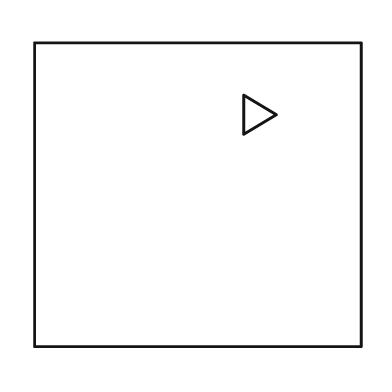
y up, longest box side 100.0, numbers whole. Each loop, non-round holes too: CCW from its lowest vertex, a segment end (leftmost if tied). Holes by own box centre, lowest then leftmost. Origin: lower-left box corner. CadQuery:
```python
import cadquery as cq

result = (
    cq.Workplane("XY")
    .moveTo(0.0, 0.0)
    .lineTo(100.0, 0.0)
    .lineTo(100.0, 93.0)
    .lineTo(0.0, 93.0)
    .close()
    .moveTo(64.0, 65.0)
    .lineTo(74.0, 71.0)
    .lineTo(64.0, 77.0)
    .close()
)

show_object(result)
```